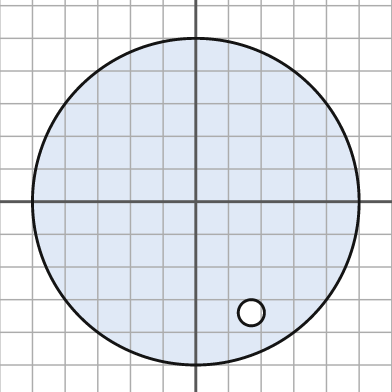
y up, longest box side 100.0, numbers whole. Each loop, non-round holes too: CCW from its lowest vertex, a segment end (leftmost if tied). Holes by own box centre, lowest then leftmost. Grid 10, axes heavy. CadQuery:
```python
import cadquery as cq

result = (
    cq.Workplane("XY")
    .moveTo(0.0, 0.0)
    .circle(50.0)
    .moveTo(17.0, -34.0)
    .circle(4.0)
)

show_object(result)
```